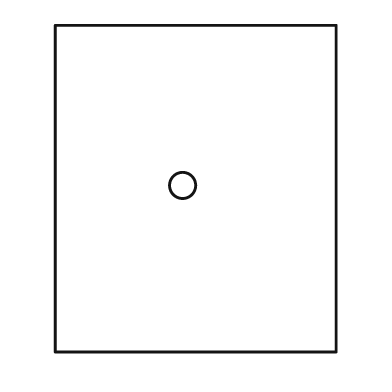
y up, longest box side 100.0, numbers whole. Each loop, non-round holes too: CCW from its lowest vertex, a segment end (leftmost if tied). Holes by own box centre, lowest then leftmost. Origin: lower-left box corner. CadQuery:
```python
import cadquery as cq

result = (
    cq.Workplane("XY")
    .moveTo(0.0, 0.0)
    .lineTo(86.0, 0.0)
    .lineTo(86.0, 100.0)
    .lineTo(0.0, 100.0)
    .close()
    .moveTo(39.0, 51.0)
    .circle(4.0)
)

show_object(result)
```